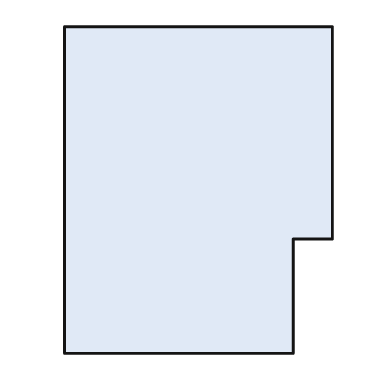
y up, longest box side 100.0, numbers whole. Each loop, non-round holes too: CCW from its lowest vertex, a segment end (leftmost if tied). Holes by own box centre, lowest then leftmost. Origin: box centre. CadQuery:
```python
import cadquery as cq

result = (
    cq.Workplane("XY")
    .moveTo(-41.0, -50.0)
    .lineTo(29.0, -50.0)
    .lineTo(29.0, -15.0)
    .lineTo(41.0, -15.0)
    .lineTo(41.0, 50.0)
    .lineTo(-41.0, 50.0)
    .close()
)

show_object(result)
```